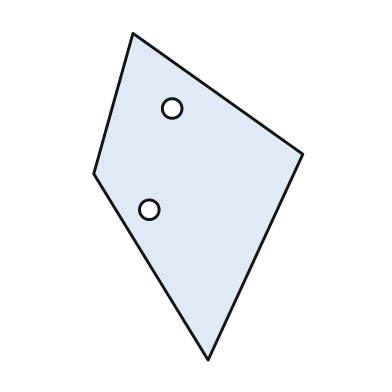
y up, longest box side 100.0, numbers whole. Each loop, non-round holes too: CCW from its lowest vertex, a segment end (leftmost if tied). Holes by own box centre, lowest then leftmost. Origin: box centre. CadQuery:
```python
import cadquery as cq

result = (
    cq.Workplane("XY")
    .moveTo(3.0, -50.0)
    .lineTo(32.0, 13.0)
    .lineTo(-20.0, 50.0)
    .lineTo(-32.0, 7.0)
    .close()
    .moveTo(-15.0, -4.0)
    .circle(3.0)
    .moveTo(-8.0, 27.0)
    .circle(3.0)
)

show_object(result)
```